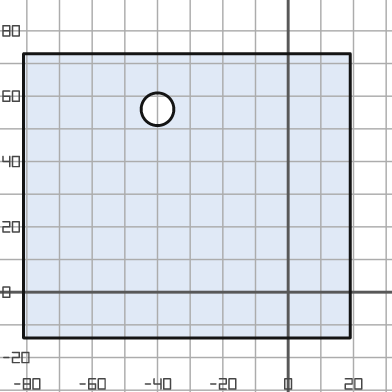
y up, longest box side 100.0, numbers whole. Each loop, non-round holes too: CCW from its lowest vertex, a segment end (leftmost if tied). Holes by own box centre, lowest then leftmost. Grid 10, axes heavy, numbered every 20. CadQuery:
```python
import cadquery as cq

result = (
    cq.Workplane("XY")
    .moveTo(-81.0, -14.0)
    .lineTo(19.0, -14.0)
    .lineTo(19.0, 73.0)
    .lineTo(-81.0, 73.0)
    .close()
    .moveTo(-40.0, 56.0)
    .circle(5.0)
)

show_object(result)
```